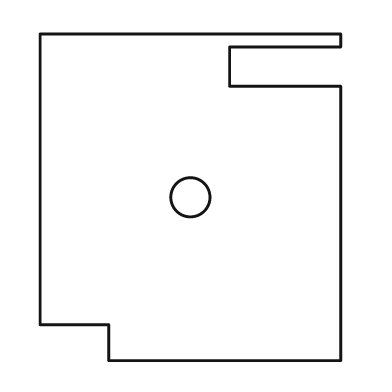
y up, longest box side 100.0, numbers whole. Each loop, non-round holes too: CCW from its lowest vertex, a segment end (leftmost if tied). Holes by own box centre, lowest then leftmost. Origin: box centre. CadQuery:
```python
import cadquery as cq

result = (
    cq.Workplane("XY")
    .moveTo(-25.0, -50.0)
    .lineTo(46.0, -50.0)
    .lineTo(46.0, 34.0)
    .lineTo(12.0, 34.0)
    .lineTo(12.0, 46.0)
    .lineTo(46.0, 46.0)
    .lineTo(46.0, 50.0)
    .lineTo(-46.0, 50.0)
    .lineTo(-46.0, -39.0)
    .lineTo(-25.0, -39.0)
    .close()
    .moveTo(0.0, 0.0)
    .circle(6.0)
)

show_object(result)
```